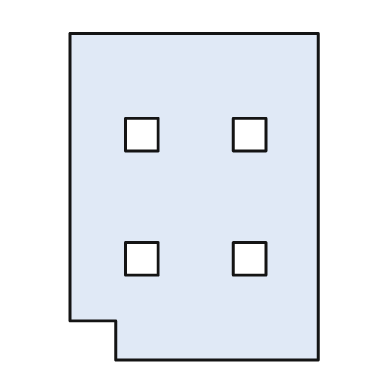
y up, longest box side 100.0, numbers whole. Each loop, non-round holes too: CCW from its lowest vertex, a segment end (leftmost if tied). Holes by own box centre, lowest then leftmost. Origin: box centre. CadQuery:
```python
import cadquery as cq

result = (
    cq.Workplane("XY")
    .moveTo(-24.0, -50.0)
    .lineTo(38.0, -50.0)
    .lineTo(38.0, 50.0)
    .lineTo(-38.0, 50.0)
    .lineTo(-38.0, -38.0)
    .lineTo(-24.0, -38.0)
    .close()
    .moveTo(-21.0, -24.0)
    .lineTo(-11.0, -24.0)
    .lineTo(-11.0, -14.0)
    .lineTo(-21.0, -14.0)
    .close()
    .moveTo(12.0, -24.0)
    .lineTo(22.0, -24.0)
    .lineTo(22.0, -14.0)
    .lineTo(12.0, -14.0)
    .close()
    .moveTo(-21.0, 14.0)
    .lineTo(-11.0, 14.0)
    .lineTo(-11.0, 24.0)
    .lineTo(-21.0, 24.0)
    .close()
    .moveTo(12.0, 14.0)
    .lineTo(22.0, 14.0)
    .lineTo(22.0, 24.0)
    .lineTo(12.0, 24.0)
    .close()
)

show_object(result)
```